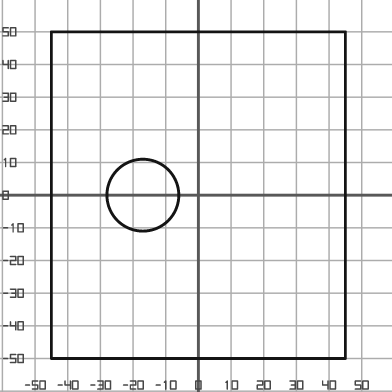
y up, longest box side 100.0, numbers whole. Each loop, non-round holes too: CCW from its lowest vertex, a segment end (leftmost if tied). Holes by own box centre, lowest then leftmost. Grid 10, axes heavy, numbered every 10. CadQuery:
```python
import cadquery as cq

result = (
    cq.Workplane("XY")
    .moveTo(-45.0, -50.0)
    .lineTo(45.0, -50.0)
    .lineTo(45.0, 50.0)
    .lineTo(-45.0, 50.0)
    .close()
    .moveTo(-17.0, 0.0)
    .circle(11.0)
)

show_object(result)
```